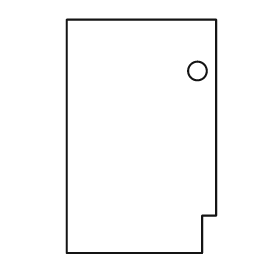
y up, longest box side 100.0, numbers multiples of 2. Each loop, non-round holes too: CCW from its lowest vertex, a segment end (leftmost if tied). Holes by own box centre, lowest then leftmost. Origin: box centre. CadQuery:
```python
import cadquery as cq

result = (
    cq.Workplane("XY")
    .moveTo(-32.0, -50.0)
    .lineTo(26.0, -50.0)
    .lineTo(26.0, -34.0)
    .lineTo(32.0, -34.0)
    .lineTo(32.0, 50.0)
    .lineTo(-32.0, 50.0)
    .close()
    .moveTo(24.0, 28.0)
    .circle(4.0)
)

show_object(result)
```